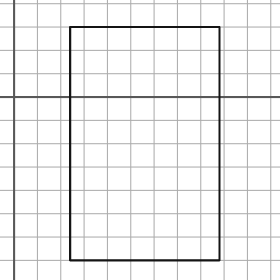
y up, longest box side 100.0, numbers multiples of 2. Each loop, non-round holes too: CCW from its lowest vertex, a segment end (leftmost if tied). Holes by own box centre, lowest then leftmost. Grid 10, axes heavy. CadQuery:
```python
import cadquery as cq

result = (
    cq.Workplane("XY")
    .moveTo(24.0, -70.0)
    .lineTo(88.0, -70.0)
    .lineTo(88.0, 30.0)
    .lineTo(24.0, 30.0)
    .close()
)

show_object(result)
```